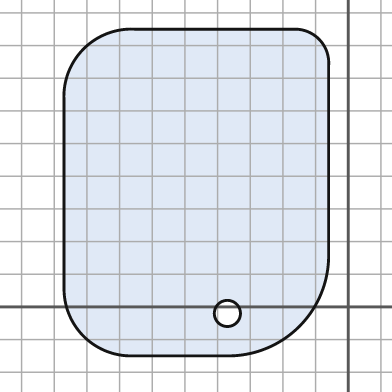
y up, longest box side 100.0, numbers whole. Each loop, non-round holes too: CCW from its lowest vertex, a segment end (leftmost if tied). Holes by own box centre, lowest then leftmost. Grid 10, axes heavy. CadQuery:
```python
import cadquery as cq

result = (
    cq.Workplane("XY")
    .moveTo(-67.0, -15.0)
    .lineTo(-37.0, -15.0)
    .threePointArc((-15.0, -6.0), (-6.0, 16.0))
    .lineTo(-6.0, 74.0)
    .threePointArc((-9.0, 82.0), (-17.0, 85.0))
    .lineTo(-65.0, 85.0)
    .threePointArc((-81.0, 79.0), (-87.0, 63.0))
    .lineTo(-87.0, 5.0)
    .threePointArc((-81.0, -9.0), (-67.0, -15.0))
    .close()
    .moveTo(-37.0, -2.0)
    .circle(4.0)
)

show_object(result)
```